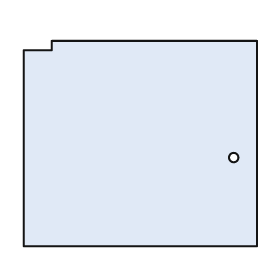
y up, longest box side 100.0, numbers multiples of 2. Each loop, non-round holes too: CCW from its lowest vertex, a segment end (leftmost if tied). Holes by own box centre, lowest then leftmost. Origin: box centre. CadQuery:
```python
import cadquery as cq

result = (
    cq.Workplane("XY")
    .moveTo(-50.0, -44.0)
    .lineTo(50.0, -44.0)
    .lineTo(50.0, 44.0)
    .lineTo(-38.0, 44.0)
    .lineTo(-38.0, 40.0)
    .lineTo(-50.0, 40.0)
    .close()
    .moveTo(40.0, -6.0)
    .circle(2.0)
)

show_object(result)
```